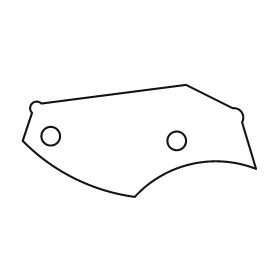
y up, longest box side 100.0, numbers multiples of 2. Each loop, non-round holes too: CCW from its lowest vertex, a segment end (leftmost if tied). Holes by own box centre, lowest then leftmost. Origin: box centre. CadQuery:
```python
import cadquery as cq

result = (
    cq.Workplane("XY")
    .moveTo(-2.0, -24.0)
    .threePointArc((22.0, -10.0), (50.0, -12.0))
    .lineTo(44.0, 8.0)
    .threePointArc((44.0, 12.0), (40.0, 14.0))
    .lineTo(20.0, 24.0)
    .lineTo(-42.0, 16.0)
    .threePointArc((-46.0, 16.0), (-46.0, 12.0))
    .lineTo(-50.0, 0.0)
    .threePointArc((-28.0, -16.0), (-2.0, -24.0))
    .close()
    .moveTo(16.0, 0.0)
    .circle(4.0)
    .moveTo(-38.0, 2.0)
    .circle(4.0)
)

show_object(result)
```